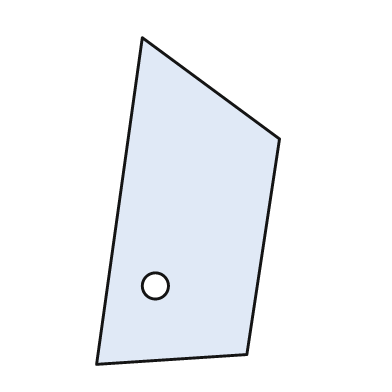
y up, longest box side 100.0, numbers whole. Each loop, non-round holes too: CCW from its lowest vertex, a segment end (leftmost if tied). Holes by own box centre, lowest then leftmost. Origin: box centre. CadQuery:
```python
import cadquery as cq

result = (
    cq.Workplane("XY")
    .moveTo(-28.0, -50.0)
    .lineTo(18.0, -47.0)
    .lineTo(28.0, 19.0)
    .lineTo(-14.0, 50.0)
    .close()
    .moveTo(-10.0, -26.0)
    .circle(4.0)
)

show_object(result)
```